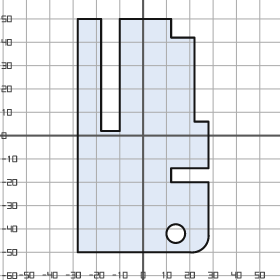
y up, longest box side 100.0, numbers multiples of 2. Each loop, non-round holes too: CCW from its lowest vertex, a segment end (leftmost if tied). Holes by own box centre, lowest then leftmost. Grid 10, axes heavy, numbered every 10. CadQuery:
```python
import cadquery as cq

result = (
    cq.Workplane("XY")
    .moveTo(-28.0, -50.0)
    .lineTo(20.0, -50.0)
    .threePointArc((26.0, -48.0), (28.0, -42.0))
    .lineTo(28.0, -20.0)
    .lineTo(12.0, -20.0)
    .lineTo(12.0, -14.0)
    .lineTo(28.0, -14.0)
    .lineTo(28.0, 6.0)
    .lineTo(22.0, 6.0)
    .lineTo(22.0, 42.0)
    .lineTo(12.0, 42.0)
    .lineTo(12.0, 50.0)
    .lineTo(-10.0, 50.0)
    .lineTo(-10.0, 2.0)
    .lineTo(-18.0, 2.0)
    .lineTo(-18.0, 50.0)
    .lineTo(-28.0, 50.0)
    .close()
    .moveTo(14.0, -42.0)
    .circle(4.0)
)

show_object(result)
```